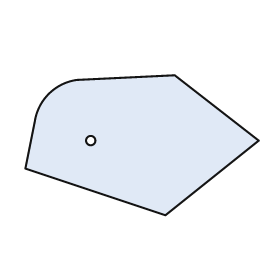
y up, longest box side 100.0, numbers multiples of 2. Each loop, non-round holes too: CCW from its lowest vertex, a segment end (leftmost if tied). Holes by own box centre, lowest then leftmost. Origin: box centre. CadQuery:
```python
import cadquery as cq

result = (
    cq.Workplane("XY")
    .moveTo(10.0, -30.0)
    .lineTo(50.0, 2.0)
    .lineTo(14.0, 30.0)
    .lineTo(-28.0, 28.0)
    .threePointArc((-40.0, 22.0), (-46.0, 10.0))
    .lineTo(-50.0, -10.0)
    .close()
    .moveTo(-22.0, 2.0)
    .circle(2.0)
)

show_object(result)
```